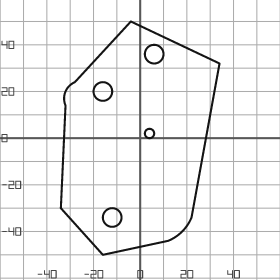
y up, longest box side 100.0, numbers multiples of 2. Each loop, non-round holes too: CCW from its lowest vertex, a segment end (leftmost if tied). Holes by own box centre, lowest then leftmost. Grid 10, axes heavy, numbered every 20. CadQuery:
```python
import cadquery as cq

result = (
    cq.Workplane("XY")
    .moveTo(-16.0, -50.0)
    .lineTo(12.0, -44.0)
    .threePointArc((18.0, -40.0), (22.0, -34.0))
    .lineTo(34.0, 32.0)
    .lineTo(-4.0, 50.0)
    .lineTo(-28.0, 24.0)
    .threePointArc((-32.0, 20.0), (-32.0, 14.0))
    .lineTo(-34.0, -30.0)
    .close()
    .moveTo(-12.0, -34.0)
    .circle(4.0)
    .moveTo(4.0, 2.0)
    .circle(2.0)
    .moveTo(-16.0, 20.0)
    .circle(4.0)
    .moveTo(6.0, 36.0)
    .circle(4.0)
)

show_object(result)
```